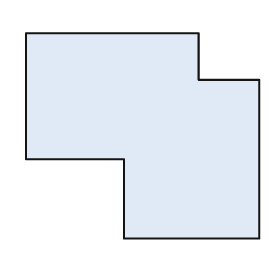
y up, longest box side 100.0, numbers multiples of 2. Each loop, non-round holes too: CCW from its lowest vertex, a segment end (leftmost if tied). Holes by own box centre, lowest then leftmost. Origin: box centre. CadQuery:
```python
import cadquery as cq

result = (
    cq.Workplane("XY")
    .moveTo(-8.0, -44.0)
    .lineTo(50.0, -44.0)
    .lineTo(50.0, 24.0)
    .lineTo(24.0, 24.0)
    .lineTo(24.0, 44.0)
    .lineTo(-50.0, 44.0)
    .lineTo(-50.0, -10.0)
    .lineTo(-8.0, -10.0)
    .close()
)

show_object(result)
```